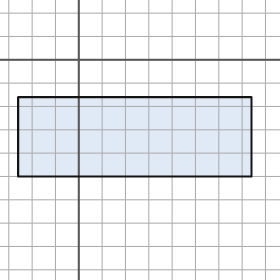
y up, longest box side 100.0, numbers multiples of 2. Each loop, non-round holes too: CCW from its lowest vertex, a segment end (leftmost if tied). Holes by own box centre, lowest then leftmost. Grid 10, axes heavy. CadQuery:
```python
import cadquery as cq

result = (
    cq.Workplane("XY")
    .moveTo(-26.0, -50.0)
    .lineTo(74.0, -50.0)
    .lineTo(74.0, -16.0)
    .lineTo(-26.0, -16.0)
    .close()
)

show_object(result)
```